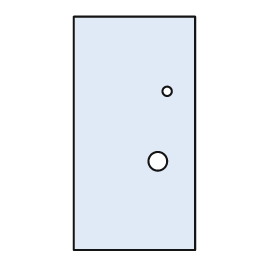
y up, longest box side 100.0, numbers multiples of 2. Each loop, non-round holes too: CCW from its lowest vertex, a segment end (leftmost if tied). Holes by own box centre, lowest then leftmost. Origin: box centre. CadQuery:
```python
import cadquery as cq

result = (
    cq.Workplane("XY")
    .moveTo(-26.0, -50.0)
    .lineTo(26.0, -50.0)
    .lineTo(26.0, 50.0)
    .lineTo(-26.0, 50.0)
    .close()
    .moveTo(10.0, -12.0)
    .circle(4.0)
    .moveTo(14.0, 18.0)
    .circle(2.0)
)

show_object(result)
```